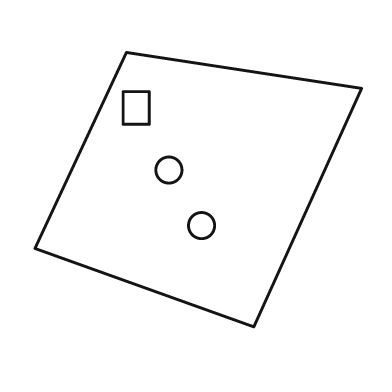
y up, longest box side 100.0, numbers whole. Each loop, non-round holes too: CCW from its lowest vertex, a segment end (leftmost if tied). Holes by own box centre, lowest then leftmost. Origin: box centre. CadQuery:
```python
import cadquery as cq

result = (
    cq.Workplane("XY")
    .moveTo(17.0, -42.0)
    .lineTo(50.0, 31.0)
    .lineTo(-22.0, 42.0)
    .lineTo(-50.0, -18.0)
    .close()
    .moveTo(1.0, -11.0)
    .circle(4.0)
    .moveTo(-9.0, 6.0)
    .circle(4.0)
    .moveTo(-23.0, 20.0)
    .lineTo(-15.0, 20.0)
    .lineTo(-15.0, 30.0)
    .lineTo(-23.0, 30.0)
    .close()
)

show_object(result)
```